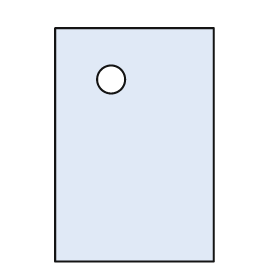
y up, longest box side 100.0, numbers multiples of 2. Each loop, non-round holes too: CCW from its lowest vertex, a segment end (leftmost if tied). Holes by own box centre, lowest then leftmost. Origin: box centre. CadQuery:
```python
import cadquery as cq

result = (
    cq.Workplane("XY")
    .moveTo(-34.0, -50.0)
    .lineTo(34.0, -50.0)
    .lineTo(34.0, 50.0)
    .lineTo(-34.0, 50.0)
    .close()
    .moveTo(-10.0, 28.0)
    .circle(6.0)
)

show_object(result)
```